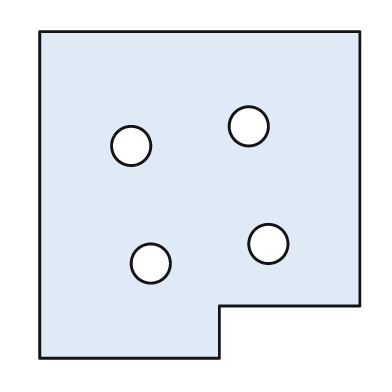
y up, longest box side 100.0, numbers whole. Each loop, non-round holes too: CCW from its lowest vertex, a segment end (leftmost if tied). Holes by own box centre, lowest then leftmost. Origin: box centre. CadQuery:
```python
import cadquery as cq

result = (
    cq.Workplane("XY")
    .moveTo(-49.0, -50.0)
    .lineTo(6.0, -50.0)
    .lineTo(6.0, -34.0)
    .lineTo(49.0, -34.0)
    .lineTo(49.0, 50.0)
    .lineTo(-49.0, 50.0)
    .close()
    .moveTo(-15.0, -21.0)
    .circle(6.0)
    .moveTo(21.0, -15.0)
    .circle(6.0)
    .moveTo(-21.0, 15.0)
    .circle(6.0)
    .moveTo(15.0, 21.0)
    .circle(6.0)
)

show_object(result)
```